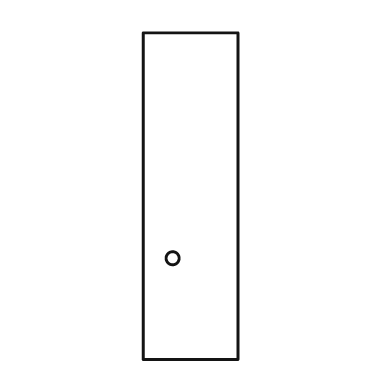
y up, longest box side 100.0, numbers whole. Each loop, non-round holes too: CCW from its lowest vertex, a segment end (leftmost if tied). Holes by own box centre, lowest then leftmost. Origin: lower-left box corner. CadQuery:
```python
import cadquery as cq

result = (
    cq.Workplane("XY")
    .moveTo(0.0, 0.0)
    .lineTo(29.0, 0.0)
    .lineTo(29.0, 100.0)
    .lineTo(0.0, 100.0)
    .close()
    .moveTo(9.0, 31.0)
    .circle(2.0)
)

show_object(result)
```